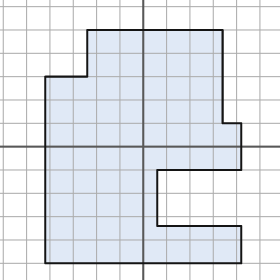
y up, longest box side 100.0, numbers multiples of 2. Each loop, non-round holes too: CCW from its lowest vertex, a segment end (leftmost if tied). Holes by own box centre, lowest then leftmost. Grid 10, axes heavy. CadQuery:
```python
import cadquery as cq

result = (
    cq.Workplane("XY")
    .moveTo(-42.0, -50.0)
    .lineTo(42.0, -50.0)
    .lineTo(42.0, -34.0)
    .lineTo(6.0, -34.0)
    .lineTo(6.0, -10.0)
    .lineTo(42.0, -10.0)
    .lineTo(42.0, 10.0)
    .lineTo(34.0, 10.0)
    .lineTo(34.0, 50.0)
    .lineTo(-24.0, 50.0)
    .lineTo(-24.0, 30.0)
    .lineTo(-42.0, 30.0)
    .close()
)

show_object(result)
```